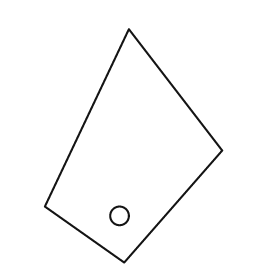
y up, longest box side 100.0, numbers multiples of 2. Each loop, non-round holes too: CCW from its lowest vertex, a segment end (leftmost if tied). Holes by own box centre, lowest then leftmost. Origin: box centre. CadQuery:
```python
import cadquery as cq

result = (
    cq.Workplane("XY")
    .moveTo(-4.0, -50.0)
    .lineTo(38.0, -2.0)
    .lineTo(-2.0, 50.0)
    .lineTo(-38.0, -26.0)
    .close()
    .moveTo(-6.0, -30.0)
    .circle(4.0)
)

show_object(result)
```